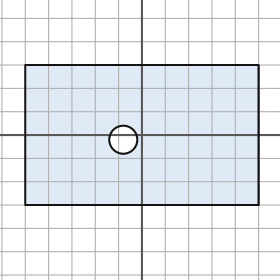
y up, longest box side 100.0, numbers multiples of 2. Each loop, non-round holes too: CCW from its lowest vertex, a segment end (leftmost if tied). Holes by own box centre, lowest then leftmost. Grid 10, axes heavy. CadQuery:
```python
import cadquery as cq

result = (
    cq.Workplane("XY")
    .moveTo(-50.0, -30.0)
    .lineTo(50.0, -30.0)
    .lineTo(50.0, 30.0)
    .lineTo(-50.0, 30.0)
    .close()
    .moveTo(-8.0, -2.0)
    .circle(6.0)
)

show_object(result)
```